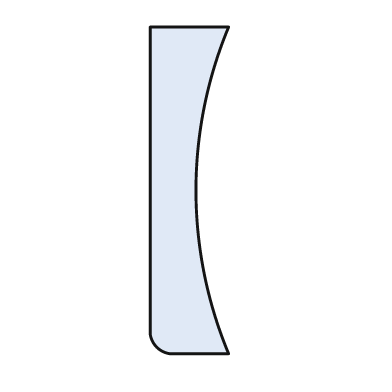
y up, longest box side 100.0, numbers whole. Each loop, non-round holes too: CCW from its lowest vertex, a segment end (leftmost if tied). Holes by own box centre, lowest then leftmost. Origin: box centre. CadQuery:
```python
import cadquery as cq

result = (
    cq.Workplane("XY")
    .moveTo(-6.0, -50.0)
    .lineTo(12.0, -50.0)
    .threePointArc((2.0, 0.0), (12.0, 50.0))
    .lineTo(-12.0, 50.0)
    .lineTo(-12.0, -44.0)
    .threePointArc((-10.0, -48.0), (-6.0, -50.0))
    .close()
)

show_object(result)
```